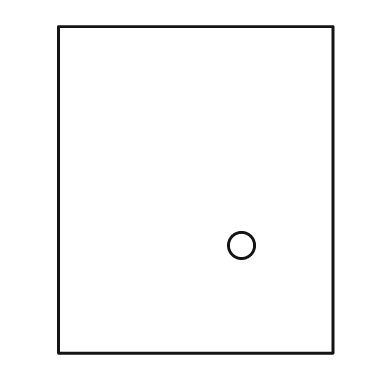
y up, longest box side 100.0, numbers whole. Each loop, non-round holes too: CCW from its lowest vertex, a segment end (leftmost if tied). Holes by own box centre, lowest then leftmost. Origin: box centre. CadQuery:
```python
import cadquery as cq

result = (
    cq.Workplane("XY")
    .moveTo(-42.0, -50.0)
    .lineTo(42.0, -50.0)
    .lineTo(42.0, 50.0)
    .lineTo(-42.0, 50.0)
    .close()
    .moveTo(14.0, -17.0)
    .circle(4.0)
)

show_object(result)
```